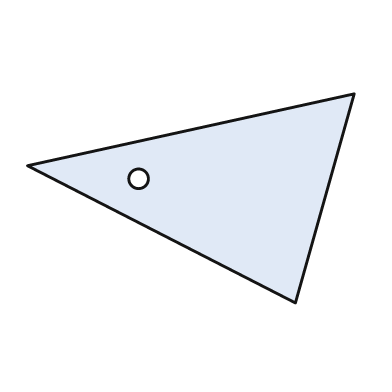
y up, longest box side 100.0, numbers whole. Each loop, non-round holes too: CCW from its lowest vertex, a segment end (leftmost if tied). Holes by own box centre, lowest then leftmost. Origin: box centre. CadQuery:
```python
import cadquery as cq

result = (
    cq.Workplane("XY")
    .moveTo(32.0, -32.0)
    .lineTo(50.0, 32.0)
    .lineTo(-50.0, 10.0)
    .close()
    .moveTo(-16.0, 6.0)
    .circle(3.0)
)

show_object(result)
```